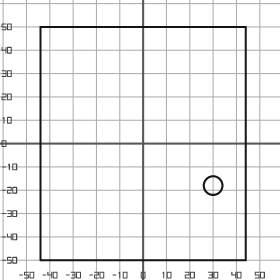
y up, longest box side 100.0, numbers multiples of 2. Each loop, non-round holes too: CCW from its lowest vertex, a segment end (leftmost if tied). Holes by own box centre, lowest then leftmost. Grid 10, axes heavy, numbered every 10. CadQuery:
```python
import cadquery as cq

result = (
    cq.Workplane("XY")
    .moveTo(-44.0, -50.0)
    .lineTo(44.0, -50.0)
    .lineTo(44.0, 50.0)
    .lineTo(-44.0, 50.0)
    .close()
    .moveTo(30.0, -18.0)
    .circle(4.0)
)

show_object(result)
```